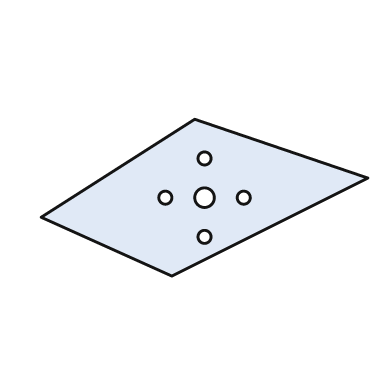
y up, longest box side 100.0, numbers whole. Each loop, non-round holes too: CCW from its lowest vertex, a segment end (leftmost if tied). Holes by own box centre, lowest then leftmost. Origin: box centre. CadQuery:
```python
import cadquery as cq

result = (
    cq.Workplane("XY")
    .moveTo(-10.0, -24.0)
    .lineTo(50.0, 6.0)
    .lineTo(-3.0, 24.0)
    .lineTo(-50.0, -6.0)
    .close()
    .moveTo(0.0, -12.0)
    .circle(2.0)
    .moveTo(-12.0, 0.0)
    .circle(2.0)
    .moveTo(0.0, 0.0)
    .circle(3.0)
    .moveTo(12.0, 0.0)
    .circle(2.0)
    .moveTo(0.0, 12.0)
    .circle(2.0)
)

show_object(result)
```